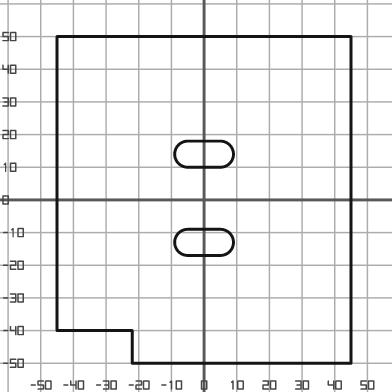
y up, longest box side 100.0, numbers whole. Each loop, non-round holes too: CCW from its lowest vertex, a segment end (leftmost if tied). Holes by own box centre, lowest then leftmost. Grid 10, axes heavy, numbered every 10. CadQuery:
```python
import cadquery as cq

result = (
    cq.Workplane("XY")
    .moveTo(-22.0, -50.0)
    .lineTo(45.0, -50.0)
    .lineTo(45.0, 50.0)
    .lineTo(-45.0, 50.0)
    .lineTo(-45.0, -40.0)
    .lineTo(-22.0, -40.0)
    .close()
    .moveTo(-5.0, -17.0)
    .lineTo(5.0, -17.0)
    .threePointArc((9.0, -13.0), (5.0, -9.0))
    .lineTo(-5.0, -9.0)
    .threePointArc((-9.0, -13.0), (-5.0, -17.0))
    .close()
    .moveTo(-5.0, 10.0)
    .lineTo(5.0, 10.0)
    .threePointArc((9.0, 14.0), (5.0, 18.0))
    .lineTo(-5.0, 18.0)
    .threePointArc((-9.0, 14.0), (-5.0, 10.0))
    .close()
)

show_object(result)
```